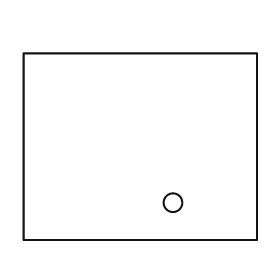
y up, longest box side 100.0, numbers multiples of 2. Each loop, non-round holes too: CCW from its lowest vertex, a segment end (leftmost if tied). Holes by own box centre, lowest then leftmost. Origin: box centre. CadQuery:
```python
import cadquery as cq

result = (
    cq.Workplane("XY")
    .moveTo(-50.0, -40.0)
    .lineTo(50.0, -40.0)
    .lineTo(50.0, 40.0)
    .lineTo(-50.0, 40.0)
    .close()
    .moveTo(14.0, -24.0)
    .circle(4.0)
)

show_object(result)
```